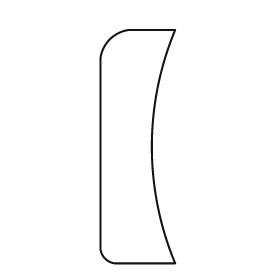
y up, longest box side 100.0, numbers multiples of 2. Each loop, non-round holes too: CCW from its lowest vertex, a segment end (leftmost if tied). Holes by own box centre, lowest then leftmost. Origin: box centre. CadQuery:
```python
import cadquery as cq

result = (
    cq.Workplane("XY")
    .moveTo(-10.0, -50.0)
    .lineTo(16.0, -50.0)
    .threePointArc((6.0, 0.0), (16.0, 50.0))
    .lineTo(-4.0, 50.0)
    .threePointArc((-12.0, 46.0), (-16.0, 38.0))
    .lineTo(-16.0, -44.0)
    .threePointArc((-14.0, -48.0), (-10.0, -50.0))
    .close()
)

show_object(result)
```